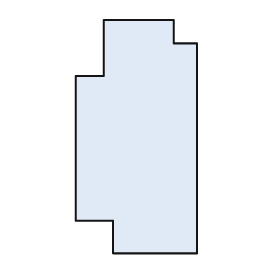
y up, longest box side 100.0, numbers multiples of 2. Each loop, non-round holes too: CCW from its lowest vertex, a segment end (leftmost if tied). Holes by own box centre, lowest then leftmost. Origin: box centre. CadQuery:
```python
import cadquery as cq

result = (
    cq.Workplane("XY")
    .moveTo(-10.0, -50.0)
    .lineTo(26.0, -50.0)
    .lineTo(26.0, 40.0)
    .lineTo(16.0, 40.0)
    .lineTo(16.0, 50.0)
    .lineTo(-14.0, 50.0)
    .lineTo(-14.0, 26.0)
    .lineTo(-26.0, 26.0)
    .lineTo(-26.0, -36.0)
    .lineTo(-10.0, -36.0)
    .close()
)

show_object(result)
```